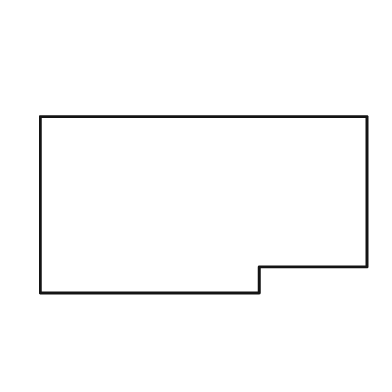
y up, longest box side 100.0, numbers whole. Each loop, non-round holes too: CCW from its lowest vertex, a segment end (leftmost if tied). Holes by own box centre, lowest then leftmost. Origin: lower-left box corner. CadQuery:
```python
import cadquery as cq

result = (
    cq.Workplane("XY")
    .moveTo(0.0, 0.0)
    .lineTo(67.0, 0.0)
    .lineTo(67.0, 8.0)
    .lineTo(100.0, 8.0)
    .lineTo(100.0, 54.0)
    .lineTo(0.0, 54.0)
    .close()
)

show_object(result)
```